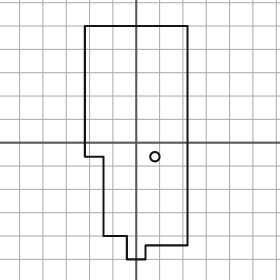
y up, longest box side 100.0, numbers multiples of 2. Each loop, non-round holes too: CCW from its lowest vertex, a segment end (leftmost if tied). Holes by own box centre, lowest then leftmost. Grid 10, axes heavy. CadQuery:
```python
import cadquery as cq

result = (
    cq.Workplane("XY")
    .moveTo(-4.0, -50.0)
    .lineTo(4.0, -50.0)
    .lineTo(4.0, -44.0)
    .lineTo(22.0, -44.0)
    .lineTo(22.0, 50.0)
    .lineTo(-22.0, 50.0)
    .lineTo(-22.0, -6.0)
    .lineTo(-14.0, -6.0)
    .lineTo(-14.0, -40.0)
    .lineTo(-4.0, -40.0)
    .close()
    .moveTo(8.0, -6.0)
    .circle(2.0)
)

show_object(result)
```